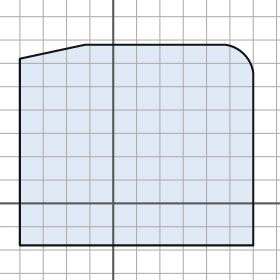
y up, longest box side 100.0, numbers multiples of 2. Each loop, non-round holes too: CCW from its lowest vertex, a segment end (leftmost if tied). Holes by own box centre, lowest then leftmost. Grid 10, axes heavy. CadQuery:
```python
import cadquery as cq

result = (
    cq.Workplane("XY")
    .moveTo(-40.0, -18.0)
    .lineTo(60.0, -18.0)
    .lineTo(60.0, 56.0)
    .threePointArc((56.0, 64.0), (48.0, 68.0))
    .lineTo(-12.0, 68.0)
    .lineTo(-40.0, 62.0)
    .close()
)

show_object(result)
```